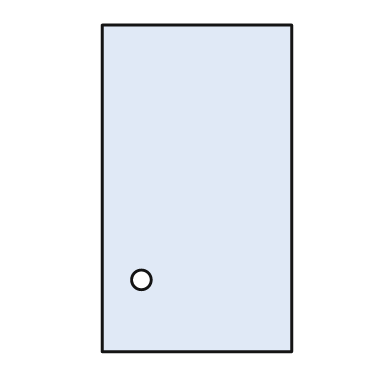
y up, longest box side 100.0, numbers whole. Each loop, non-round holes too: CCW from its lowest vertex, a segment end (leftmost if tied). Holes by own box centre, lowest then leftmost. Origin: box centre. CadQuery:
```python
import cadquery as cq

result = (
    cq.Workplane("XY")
    .moveTo(-29.0, -50.0)
    .lineTo(29.0, -50.0)
    .lineTo(29.0, 50.0)
    .lineTo(-29.0, 50.0)
    .close()
    .moveTo(-17.0, -28.0)
    .circle(3.0)
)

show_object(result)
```